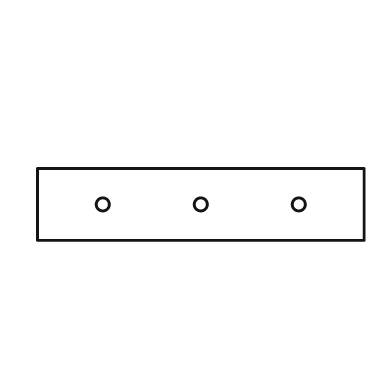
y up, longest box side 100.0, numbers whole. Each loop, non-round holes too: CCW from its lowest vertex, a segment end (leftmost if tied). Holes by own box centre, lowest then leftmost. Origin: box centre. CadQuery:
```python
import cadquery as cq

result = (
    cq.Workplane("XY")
    .moveTo(-50.0, -11.0)
    .lineTo(50.0, -11.0)
    .lineTo(50.0, 11.0)
    .lineTo(-50.0, 11.0)
    .close()
    .moveTo(-30.0, 0.0)
    .circle(2.0)
    .moveTo(0.0, 0.0)
    .circle(2.0)
    .moveTo(30.0, 0.0)
    .circle(2.0)
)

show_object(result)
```